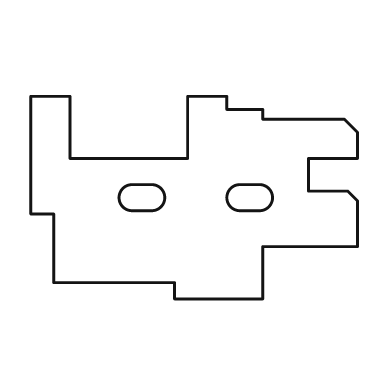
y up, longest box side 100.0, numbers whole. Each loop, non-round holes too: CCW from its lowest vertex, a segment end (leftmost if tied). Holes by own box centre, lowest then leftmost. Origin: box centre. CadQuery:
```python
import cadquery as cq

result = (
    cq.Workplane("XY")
    .moveTo(-6.0, -31.0)
    .lineTo(21.0, -31.0)
    .lineTo(21.0, -15.0)
    .lineTo(50.0, -15.0)
    .lineTo(50.0, -1.0)
    .lineTo(47.0, 2.0)
    .lineTo(35.0, 2.0)
    .lineTo(35.0, 12.0)
    .lineTo(50.0, 12.0)
    .lineTo(50.0, 20.0)
    .lineTo(46.0, 24.0)
    .lineTo(21.0, 24.0)
    .lineTo(21.0, 27.0)
    .lineTo(10.0, 27.0)
    .lineTo(10.0, 31.0)
    .lineTo(-2.0, 31.0)
    .lineTo(-2.0, 12.0)
    .lineTo(-38.0, 12.0)
    .lineTo(-38.0, 31.0)
    .lineTo(-50.0, 31.0)
    .lineTo(-50.0, -5.0)
    .lineTo(-43.0, -5.0)
    .lineTo(-43.0, -26.0)
    .lineTo(-6.0, -26.0)
    .close()
    .moveTo(-19.0, -4.0)
    .lineTo(-13.0, -4.0)
    .threePointArc((-9.0, 0.0), (-13.0, 4.0))
    .lineTo(-19.0, 4.0)
    .threePointArc((-23.0, 0.0), (-19.0, -4.0))
    .close()
    .moveTo(14.0, -4.0)
    .lineTo(20.0, -4.0)
    .threePointArc((24.0, 0.0), (20.0, 4.0))
    .lineTo(14.0, 4.0)
    .threePointArc((10.0, 0.0), (14.0, -4.0))
    .close()
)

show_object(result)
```